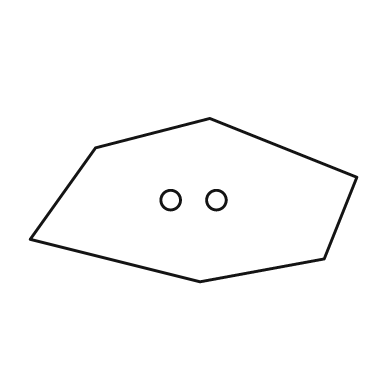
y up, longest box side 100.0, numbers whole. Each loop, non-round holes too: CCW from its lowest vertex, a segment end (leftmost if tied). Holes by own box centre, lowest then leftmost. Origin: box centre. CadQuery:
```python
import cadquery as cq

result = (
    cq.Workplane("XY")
    .moveTo(2.0, -25.0)
    .lineTo(40.0, -18.0)
    .lineTo(50.0, 7.0)
    .lineTo(5.0, 25.0)
    .lineTo(-30.0, 16.0)
    .lineTo(-50.0, -12.0)
    .close()
    .moveTo(-7.0, 0.0)
    .circle(3.0)
    .moveTo(7.0, 0.0)
    .circle(3.0)
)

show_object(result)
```